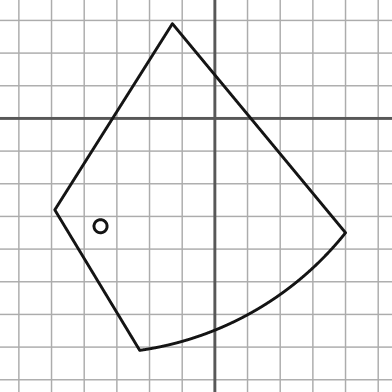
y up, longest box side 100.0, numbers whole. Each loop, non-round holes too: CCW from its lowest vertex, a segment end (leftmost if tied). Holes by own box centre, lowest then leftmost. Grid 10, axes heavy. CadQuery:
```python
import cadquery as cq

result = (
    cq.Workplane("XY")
    .moveTo(-23.0, -71.0)
    .threePointArc((12.0, -59.0), (40.0, -35.0))
    .lineTo(-13.0, 29.0)
    .lineTo(-49.0, -28.0)
    .close()
    .moveTo(-35.0, -33.0)
    .circle(2.0)
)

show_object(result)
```